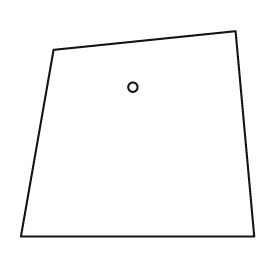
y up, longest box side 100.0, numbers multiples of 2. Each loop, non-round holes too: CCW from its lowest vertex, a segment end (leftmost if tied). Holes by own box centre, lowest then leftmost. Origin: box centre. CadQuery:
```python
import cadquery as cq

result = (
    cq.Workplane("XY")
    .moveTo(-50.0, -44.0)
    .lineTo(50.0, -44.0)
    .lineTo(42.0, 44.0)
    .lineTo(-36.0, 36.0)
    .close()
    .moveTo(-2.0, 20.0)
    .circle(2.0)
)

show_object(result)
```